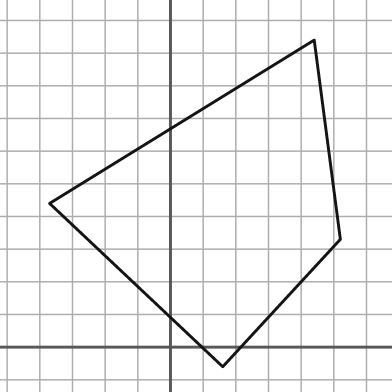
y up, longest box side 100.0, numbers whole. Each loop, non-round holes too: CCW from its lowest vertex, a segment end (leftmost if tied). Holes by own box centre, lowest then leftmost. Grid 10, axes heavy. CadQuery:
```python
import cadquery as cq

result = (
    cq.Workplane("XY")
    .moveTo(16.0, -6.0)
    .lineTo(52.0, 33.0)
    .lineTo(44.0, 94.0)
    .lineTo(-37.0, 44.0)
    .close()
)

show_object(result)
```